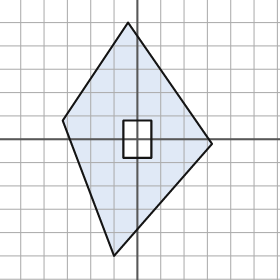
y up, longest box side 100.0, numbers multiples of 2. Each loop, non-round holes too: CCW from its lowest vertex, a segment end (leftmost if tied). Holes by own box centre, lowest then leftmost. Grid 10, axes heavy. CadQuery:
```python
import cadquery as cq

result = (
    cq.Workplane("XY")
    .moveTo(-10.0, -50.0)
    .lineTo(32.0, -2.0)
    .lineTo(-4.0, 50.0)
    .lineTo(-32.0, 8.0)
    .close()
    .moveTo(-6.0, -8.0)
    .lineTo(6.0, -8.0)
    .lineTo(6.0, 8.0)
    .lineTo(-6.0, 8.0)
    .close()
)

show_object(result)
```